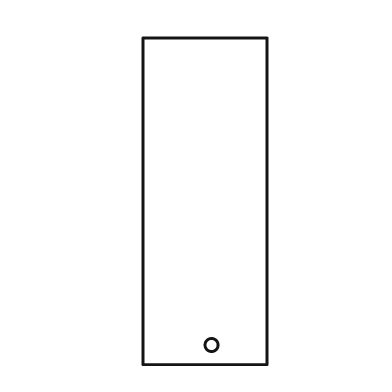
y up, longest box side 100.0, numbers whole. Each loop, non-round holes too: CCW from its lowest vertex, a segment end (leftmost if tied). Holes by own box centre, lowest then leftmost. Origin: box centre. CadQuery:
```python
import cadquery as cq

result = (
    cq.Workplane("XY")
    .moveTo(-19.0, -50.0)
    .lineTo(19.0, -50.0)
    .lineTo(19.0, 50.0)
    .lineTo(-19.0, 50.0)
    .close()
    .moveTo(2.0, -44.0)
    .circle(2.0)
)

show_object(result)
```